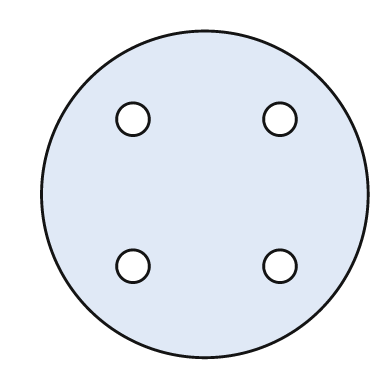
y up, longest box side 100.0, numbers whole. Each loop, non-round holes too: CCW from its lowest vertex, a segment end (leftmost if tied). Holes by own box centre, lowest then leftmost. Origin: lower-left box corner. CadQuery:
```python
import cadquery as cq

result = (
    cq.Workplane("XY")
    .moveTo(50.0, 50.0)
    .circle(50.0)
    .moveTo(28.0, 28.0)
    .circle(5.0)
    .moveTo(73.0, 28.0)
    .circle(5.0)
    .moveTo(28.0, 73.0)
    .circle(5.0)
    .moveTo(73.0, 73.0)
    .circle(5.0)
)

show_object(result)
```